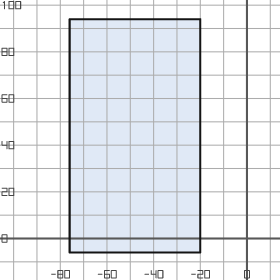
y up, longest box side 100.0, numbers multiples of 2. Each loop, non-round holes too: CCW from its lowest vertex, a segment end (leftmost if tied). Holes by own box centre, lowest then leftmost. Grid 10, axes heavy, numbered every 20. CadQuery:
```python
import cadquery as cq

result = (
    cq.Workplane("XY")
    .moveTo(-76.0, -6.0)
    .lineTo(-20.0, -6.0)
    .lineTo(-20.0, 94.0)
    .lineTo(-76.0, 94.0)
    .close()
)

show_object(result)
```